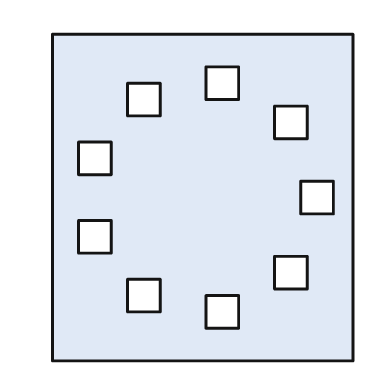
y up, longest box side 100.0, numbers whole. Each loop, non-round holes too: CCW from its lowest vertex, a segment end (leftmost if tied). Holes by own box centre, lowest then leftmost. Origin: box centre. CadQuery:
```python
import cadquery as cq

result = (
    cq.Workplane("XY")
    .moveTo(-46.0, -50.0)
    .lineTo(46.0, -50.0)
    .lineTo(46.0, 50.0)
    .lineTo(-46.0, 50.0)
    .close()
    .moveTo(1.0, -40.0)
    .lineTo(11.0, -40.0)
    .lineTo(11.0, -30.0)
    .lineTo(1.0, -30.0)
    .close()
    .moveTo(-23.0, -35.0)
    .lineTo(-13.0, -35.0)
    .lineTo(-13.0, -25.0)
    .lineTo(-23.0, -25.0)
    .close()
    .moveTo(22.0, -28.0)
    .lineTo(32.0, -28.0)
    .lineTo(32.0, -18.0)
    .lineTo(22.0, -18.0)
    .close()
    .moveTo(-38.0, -17.0)
    .lineTo(-28.0, -17.0)
    .lineTo(-28.0, -7.0)
    .lineTo(-38.0, -7.0)
    .close()
    .moveTo(30.0, -5.0)
    .lineTo(40.0, -5.0)
    .lineTo(40.0, 5.0)
    .lineTo(30.0, 5.0)
    .close()
    .moveTo(-38.0, 7.0)
    .lineTo(-28.0, 7.0)
    .lineTo(-28.0, 17.0)
    .lineTo(-38.0, 17.0)
    .close()
    .moveTo(22.0, 18.0)
    .lineTo(32.0, 18.0)
    .lineTo(32.0, 28.0)
    .lineTo(22.0, 28.0)
    .close()
    .moveTo(-23.0, 25.0)
    .lineTo(-13.0, 25.0)
    .lineTo(-13.0, 35.0)
    .lineTo(-23.0, 35.0)
    .close()
    .moveTo(1.0, 30.0)
    .lineTo(11.0, 30.0)
    .lineTo(11.0, 40.0)
    .lineTo(1.0, 40.0)
    .close()
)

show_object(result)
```